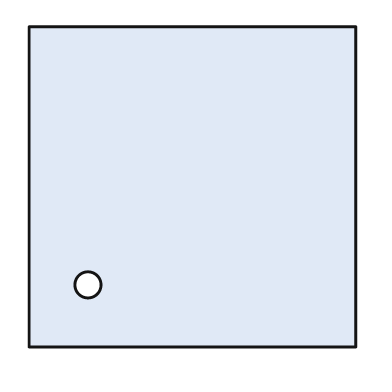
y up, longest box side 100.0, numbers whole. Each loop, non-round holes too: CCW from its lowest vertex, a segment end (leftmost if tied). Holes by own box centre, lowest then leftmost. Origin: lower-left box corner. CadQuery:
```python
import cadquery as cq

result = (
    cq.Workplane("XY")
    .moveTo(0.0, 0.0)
    .lineTo(100.0, 0.0)
    .lineTo(100.0, 98.0)
    .lineTo(0.0, 98.0)
    .close()
    .moveTo(18.0, 19.0)
    .circle(4.0)
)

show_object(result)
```